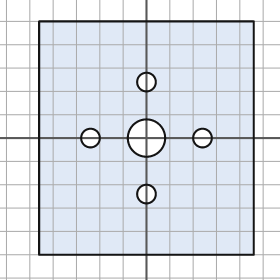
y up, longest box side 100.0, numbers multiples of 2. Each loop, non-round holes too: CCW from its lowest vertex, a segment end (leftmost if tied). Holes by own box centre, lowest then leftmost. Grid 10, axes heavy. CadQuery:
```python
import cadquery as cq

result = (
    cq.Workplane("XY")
    .moveTo(-46.0, -50.0)
    .lineTo(46.0, -50.0)
    .lineTo(46.0, 50.0)
    .lineTo(-46.0, 50.0)
    .close()
    .moveTo(0.0, -24.0)
    .circle(4.0)
    .moveTo(-24.0, 0.0)
    .circle(4.0)
    .moveTo(0.0, 0.0)
    .circle(8.0)
    .moveTo(24.0, 0.0)
    .circle(4.0)
    .moveTo(0.0, 24.0)
    .circle(4.0)
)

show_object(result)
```